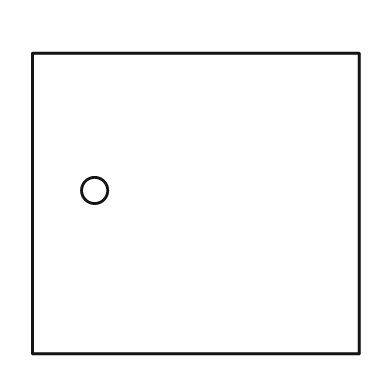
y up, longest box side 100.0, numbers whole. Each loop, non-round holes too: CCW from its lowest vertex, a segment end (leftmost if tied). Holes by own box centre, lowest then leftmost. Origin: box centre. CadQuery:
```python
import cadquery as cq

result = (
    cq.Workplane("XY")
    .moveTo(-50.0, -46.0)
    .lineTo(50.0, -46.0)
    .lineTo(50.0, 46.0)
    .lineTo(-50.0, 46.0)
    .close()
    .moveTo(-31.0, 4.0)
    .circle(4.0)
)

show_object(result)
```